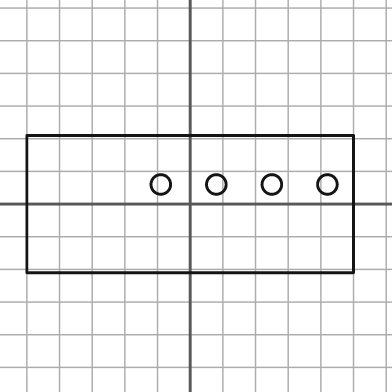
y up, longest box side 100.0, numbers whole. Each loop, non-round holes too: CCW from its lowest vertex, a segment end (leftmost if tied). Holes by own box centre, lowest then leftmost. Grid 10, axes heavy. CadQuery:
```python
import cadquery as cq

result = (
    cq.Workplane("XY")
    .moveTo(-50.0, -21.0)
    .lineTo(50.0, -21.0)
    .lineTo(50.0, 21.0)
    .lineTo(-50.0, 21.0)
    .close()
    .moveTo(-9.0, 6.0)
    .circle(3.0)
    .moveTo(8.0, 6.0)
    .circle(3.0)
    .moveTo(25.0, 6.0)
    .circle(3.0)
    .moveTo(42.0, 6.0)
    .circle(3.0)
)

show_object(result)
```